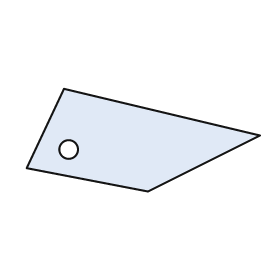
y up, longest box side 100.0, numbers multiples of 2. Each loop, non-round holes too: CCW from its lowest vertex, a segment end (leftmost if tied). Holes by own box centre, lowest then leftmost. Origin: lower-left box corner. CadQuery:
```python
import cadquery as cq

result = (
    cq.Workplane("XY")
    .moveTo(52.0, 0.0)
    .lineTo(100.0, 24.0)
    .lineTo(16.0, 44.0)
    .lineTo(0.0, 10.0)
    .close()
    .moveTo(18.0, 18.0)
    .circle(4.0)
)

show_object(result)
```